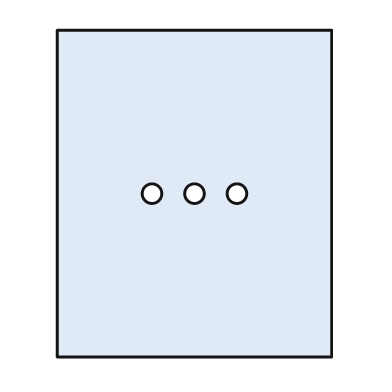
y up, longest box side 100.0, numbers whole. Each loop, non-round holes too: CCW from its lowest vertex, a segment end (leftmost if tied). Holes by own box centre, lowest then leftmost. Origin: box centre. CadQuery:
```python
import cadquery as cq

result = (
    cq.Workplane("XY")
    .moveTo(-42.0, -50.0)
    .lineTo(42.0, -50.0)
    .lineTo(42.0, 50.0)
    .lineTo(-42.0, 50.0)
    .close()
    .moveTo(-13.0, 0.0)
    .circle(3.0)
    .moveTo(0.0, 0.0)
    .circle(3.0)
    .moveTo(13.0, 0.0)
    .circle(3.0)
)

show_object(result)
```